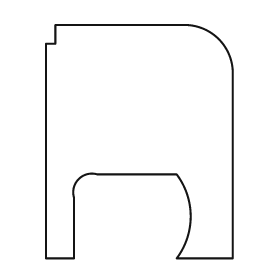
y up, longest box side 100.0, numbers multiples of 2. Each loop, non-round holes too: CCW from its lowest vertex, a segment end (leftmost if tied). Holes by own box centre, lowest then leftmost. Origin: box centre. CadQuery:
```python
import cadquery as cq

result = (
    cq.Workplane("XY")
    .moveTo(-40.0, -50.0)
    .lineTo(-28.0, -50.0)
    .lineTo(-28.0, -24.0)
    .threePointArc((-26.0, -16.0), (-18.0, -14.0))
    .lineTo(16.0, -14.0)
    .threePointArc((22.0, -32.0), (16.0, -50.0))
    .lineTo(40.0, -50.0)
    .lineTo(40.0, 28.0)
    .threePointArc((34.0, 44.0), (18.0, 50.0))
    .lineTo(-36.0, 50.0)
    .lineTo(-36.0, 42.0)
    .lineTo(-40.0, 42.0)
    .close()
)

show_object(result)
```